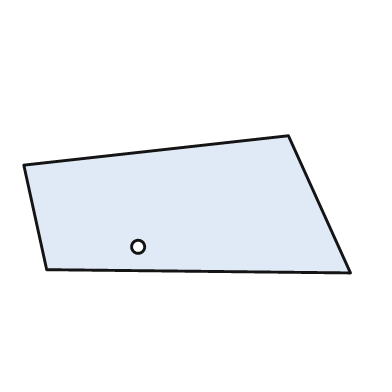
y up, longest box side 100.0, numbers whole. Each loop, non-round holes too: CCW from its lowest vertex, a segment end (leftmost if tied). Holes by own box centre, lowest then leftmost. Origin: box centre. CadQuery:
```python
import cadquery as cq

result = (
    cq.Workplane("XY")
    .moveTo(50.0, -21.0)
    .lineTo(31.0, 21.0)
    .lineTo(-50.0, 12.0)
    .lineTo(-43.0, -20.0)
    .close()
    .moveTo(-15.0, -13.0)
    .circle(2.0)
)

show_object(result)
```